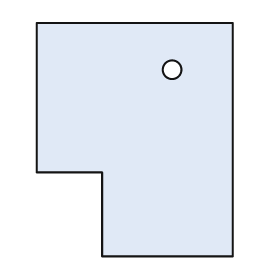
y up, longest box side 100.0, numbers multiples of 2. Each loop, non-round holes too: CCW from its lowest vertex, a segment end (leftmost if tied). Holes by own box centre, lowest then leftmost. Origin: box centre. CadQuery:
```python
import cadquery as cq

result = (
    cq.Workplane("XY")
    .moveTo(-14.0, -50.0)
    .lineTo(42.0, -50.0)
    .lineTo(42.0, 50.0)
    .lineTo(-42.0, 50.0)
    .lineTo(-42.0, -14.0)
    .lineTo(-14.0, -14.0)
    .close()
    .moveTo(16.0, 30.0)
    .circle(4.0)
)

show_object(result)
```